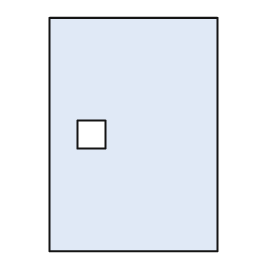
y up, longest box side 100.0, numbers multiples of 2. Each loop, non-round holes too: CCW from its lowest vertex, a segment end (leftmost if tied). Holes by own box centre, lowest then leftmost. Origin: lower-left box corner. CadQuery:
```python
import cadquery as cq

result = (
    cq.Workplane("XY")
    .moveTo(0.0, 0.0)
    .lineTo(72.0, 0.0)
    .lineTo(72.0, 100.0)
    .lineTo(0.0, 100.0)
    .close()
    .moveTo(12.0, 44.0)
    .lineTo(24.0, 44.0)
    .lineTo(24.0, 56.0)
    .lineTo(12.0, 56.0)
    .close()
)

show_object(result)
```